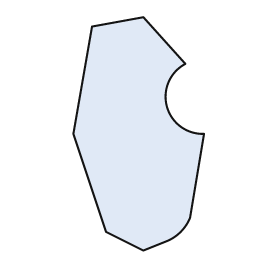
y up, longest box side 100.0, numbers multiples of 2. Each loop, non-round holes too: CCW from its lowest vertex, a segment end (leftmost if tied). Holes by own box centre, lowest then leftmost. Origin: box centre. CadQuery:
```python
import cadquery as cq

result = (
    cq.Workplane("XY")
    .moveTo(2.0, -50.0)
    .lineTo(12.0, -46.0)
    .threePointArc((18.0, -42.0), (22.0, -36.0))
    .lineTo(28.0, 0.0)
    .threePointArc((12.0, 12.0), (20.0, 30.0))
    .lineTo(2.0, 50.0)
    .lineTo(-20.0, 46.0)
    .lineTo(-28.0, 0.0)
    .lineTo(-14.0, -42.0)
    .close()
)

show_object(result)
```